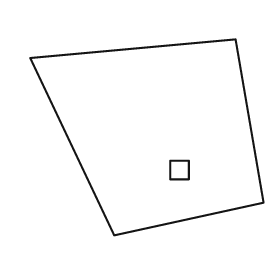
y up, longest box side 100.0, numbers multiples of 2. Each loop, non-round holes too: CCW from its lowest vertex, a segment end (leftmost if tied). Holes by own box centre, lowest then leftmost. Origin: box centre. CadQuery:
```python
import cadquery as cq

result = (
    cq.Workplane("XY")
    .moveTo(-14.0, -42.0)
    .lineTo(50.0, -28.0)
    .lineTo(38.0, 42.0)
    .lineTo(-50.0, 34.0)
    .close()
    .moveTo(10.0, -18.0)
    .lineTo(18.0, -18.0)
    .lineTo(18.0, -10.0)
    .lineTo(10.0, -10.0)
    .close()
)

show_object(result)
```